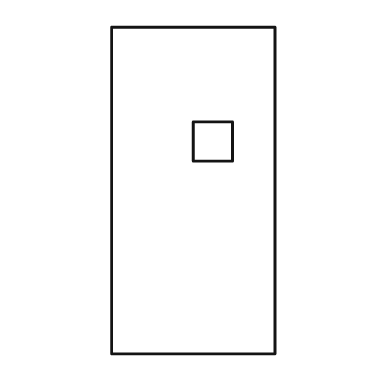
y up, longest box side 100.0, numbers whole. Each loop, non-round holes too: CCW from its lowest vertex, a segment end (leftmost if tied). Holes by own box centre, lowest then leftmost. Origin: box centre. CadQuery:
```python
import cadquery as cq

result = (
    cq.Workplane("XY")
    .moveTo(-25.0, -50.0)
    .lineTo(25.0, -50.0)
    .lineTo(25.0, 50.0)
    .lineTo(-25.0, 50.0)
    .close()
    .moveTo(0.0, 9.0)
    .lineTo(12.0, 9.0)
    .lineTo(12.0, 21.0)
    .lineTo(0.0, 21.0)
    .close()
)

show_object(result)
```